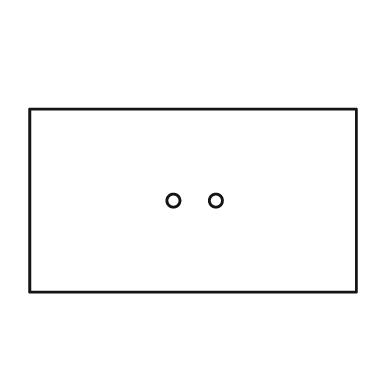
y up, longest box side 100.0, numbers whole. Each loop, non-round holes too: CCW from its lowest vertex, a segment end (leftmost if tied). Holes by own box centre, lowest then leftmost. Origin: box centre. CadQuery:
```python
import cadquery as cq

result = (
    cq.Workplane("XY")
    .moveTo(-50.0, -28.0)
    .lineTo(50.0, -28.0)
    .lineTo(50.0, 28.0)
    .lineTo(-50.0, 28.0)
    .close()
    .moveTo(-6.0, 0.0)
    .circle(2.0)
    .moveTo(7.0, 0.0)
    .circle(2.0)
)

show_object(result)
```